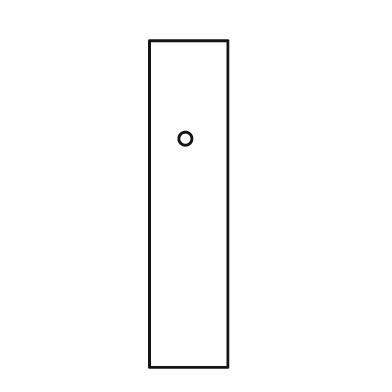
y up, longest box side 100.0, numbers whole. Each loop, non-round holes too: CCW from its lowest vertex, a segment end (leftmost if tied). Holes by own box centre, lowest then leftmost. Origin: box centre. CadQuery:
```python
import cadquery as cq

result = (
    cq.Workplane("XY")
    .moveTo(-12.0, -50.0)
    .lineTo(12.0, -50.0)
    .lineTo(12.0, 50.0)
    .lineTo(-12.0, 50.0)
    .close()
    .moveTo(-1.0, 20.0)
    .circle(2.0)
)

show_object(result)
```